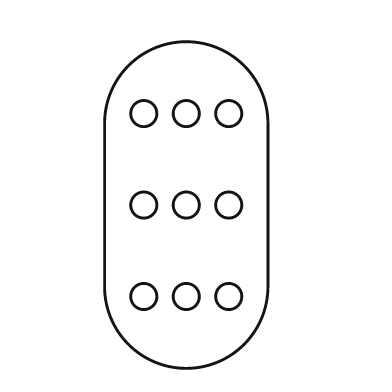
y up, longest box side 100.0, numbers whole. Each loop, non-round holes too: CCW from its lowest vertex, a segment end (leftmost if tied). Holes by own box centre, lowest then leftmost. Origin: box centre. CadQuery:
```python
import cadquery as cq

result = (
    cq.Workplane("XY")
    .moveTo(-25.0, -25.0)
    .threePointArc((0.0, -50.0), (25.0, -25.0))
    .lineTo(25.0, 25.0)
    .threePointArc((0.0, 50.0), (-25.0, 25.0))
    .close()
    .moveTo(-13.0, -28.0)
    .circle(4.0)
    .moveTo(0.0, -28.0)
    .circle(4.0)
    .moveTo(13.0, -28.0)
    .circle(4.0)
    .moveTo(-13.0, 0.0)
    .circle(4.0)
    .moveTo(0.0, 0.0)
    .circle(4.0)
    .moveTo(13.0, 0.0)
    .circle(4.0)
    .moveTo(-13.0, 28.0)
    .circle(4.0)
    .moveTo(0.0, 28.0)
    .circle(4.0)
    .moveTo(13.0, 28.0)
    .circle(4.0)
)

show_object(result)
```